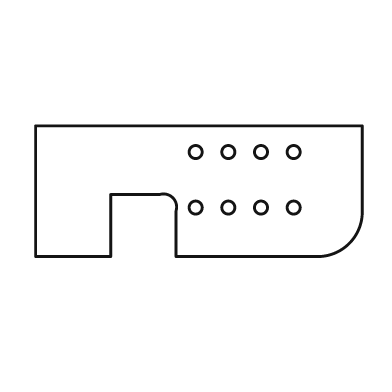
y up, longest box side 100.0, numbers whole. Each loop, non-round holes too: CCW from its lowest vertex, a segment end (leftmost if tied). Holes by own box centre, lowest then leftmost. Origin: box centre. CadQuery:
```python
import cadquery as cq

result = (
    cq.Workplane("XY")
    .moveTo(-50.0, -20.0)
    .lineTo(-27.0, -20.0)
    .lineTo(-27.0, -1.0)
    .lineTo(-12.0, -1.0)
    .threePointArc((-8.0, -2.0), (-7.0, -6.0))
    .lineTo(-7.0, -20.0)
    .lineTo(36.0, -20.0)
    .threePointArc((46.0, -16.0), (50.0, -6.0))
    .lineTo(50.0, 20.0)
    .lineTo(-50.0, 20.0)
    .close()
    .moveTo(-1.0, -5.0)
    .circle(2.0)
    .moveTo(9.0, -5.0)
    .circle(2.0)
    .moveTo(19.0, -5.0)
    .circle(2.0)
    .moveTo(29.0, -5.0)
    .circle(2.0)
    .moveTo(-1.0, 12.0)
    .circle(2.0)
    .moveTo(9.0, 12.0)
    .circle(2.0)
    .moveTo(19.0, 12.0)
    .circle(2.0)
    .moveTo(29.0, 12.0)
    .circle(2.0)
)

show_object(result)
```